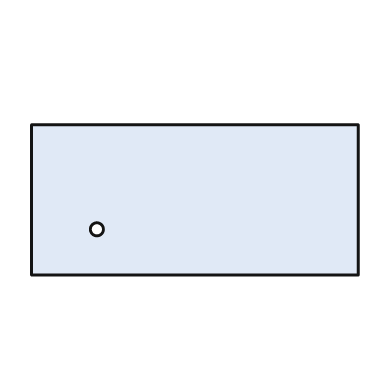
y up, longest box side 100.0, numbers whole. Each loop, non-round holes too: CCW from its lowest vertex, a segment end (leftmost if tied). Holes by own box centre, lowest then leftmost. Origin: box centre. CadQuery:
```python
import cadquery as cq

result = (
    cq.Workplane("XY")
    .moveTo(-50.0, -23.0)
    .lineTo(50.0, -23.0)
    .lineTo(50.0, 23.0)
    .lineTo(-50.0, 23.0)
    .close()
    .moveTo(-30.0, -9.0)
    .circle(2.0)
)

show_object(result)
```